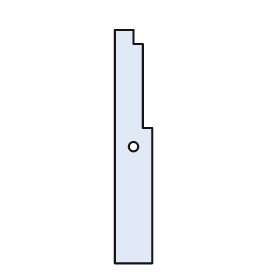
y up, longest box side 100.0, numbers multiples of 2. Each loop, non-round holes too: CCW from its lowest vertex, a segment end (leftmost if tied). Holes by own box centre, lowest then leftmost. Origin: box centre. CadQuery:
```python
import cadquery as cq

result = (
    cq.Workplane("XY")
    .moveTo(-8.0, -50.0)
    .lineTo(8.0, -50.0)
    .lineTo(8.0, 8.0)
    .lineTo(4.0, 8.0)
    .lineTo(4.0, 44.0)
    .lineTo(0.0, 44.0)
    .lineTo(0.0, 50.0)
    .lineTo(-8.0, 50.0)
    .close()
    .moveTo(0.0, 0.0)
    .circle(2.0)
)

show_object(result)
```